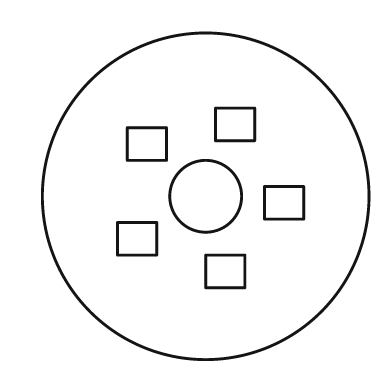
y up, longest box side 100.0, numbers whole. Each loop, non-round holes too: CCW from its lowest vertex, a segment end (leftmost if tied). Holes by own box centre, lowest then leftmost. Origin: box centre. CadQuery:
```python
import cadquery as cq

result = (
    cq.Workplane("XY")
    .moveTo(0.0, 0.0)
    .circle(50.0)
    .moveTo(0.0, -28.0)
    .lineTo(12.0, -28.0)
    .lineTo(12.0, -18.0)
    .lineTo(0.0, -18.0)
    .close()
    .moveTo(-27.0, -18.0)
    .lineTo(-15.0, -18.0)
    .lineTo(-15.0, -8.0)
    .lineTo(-27.0, -8.0)
    .close()
    .moveTo(18.0, -7.0)
    .lineTo(30.0, -7.0)
    .lineTo(30.0, 3.0)
    .lineTo(18.0, 3.0)
    .close()
    .moveTo(0.0, 0.0)
    .circle(11.0)
    .moveTo(-24.0, 11.0)
    .lineTo(-12.0, 11.0)
    .lineTo(-12.0, 21.0)
    .lineTo(-24.0, 21.0)
    .close()
    .moveTo(3.0, 17.0)
    .lineTo(15.0, 17.0)
    .lineTo(15.0, 27.0)
    .lineTo(3.0, 27.0)
    .close()
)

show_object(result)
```